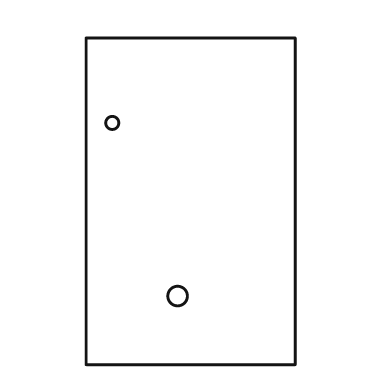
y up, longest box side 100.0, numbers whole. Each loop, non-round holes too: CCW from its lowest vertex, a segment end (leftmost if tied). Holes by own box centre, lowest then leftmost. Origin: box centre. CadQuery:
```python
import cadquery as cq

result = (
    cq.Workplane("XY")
    .moveTo(-32.0, -50.0)
    .lineTo(32.0, -50.0)
    .lineTo(32.0, 50.0)
    .lineTo(-32.0, 50.0)
    .close()
    .moveTo(-4.0, -29.0)
    .circle(3.0)
    .moveTo(-24.0, 24.0)
    .circle(2.0)
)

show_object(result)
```